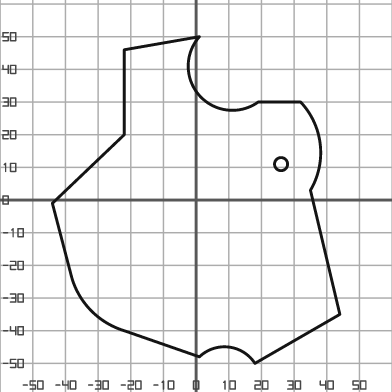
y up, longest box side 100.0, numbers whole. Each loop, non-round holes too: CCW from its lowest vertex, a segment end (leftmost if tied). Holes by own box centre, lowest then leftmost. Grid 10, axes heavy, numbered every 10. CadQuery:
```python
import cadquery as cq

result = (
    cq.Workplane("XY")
    .moveTo(18.0, -50.0)
    .lineTo(44.0, -35.0)
    .lineTo(35.0, 3.0)
    .threePointArc((38.0, 17.0), (32.0, 30.0))
    .lineTo(19.0, 30.0)
    .threePointArc((1.0, 32.0), (1.0, 50.0))
    .lineTo(-22.0, 46.0)
    .lineTo(-22.0, 20.0)
    .lineTo(-44.0, -1.0)
    .lineTo(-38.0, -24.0)
    .threePointArc((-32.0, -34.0), (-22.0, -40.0))
    .lineTo(1.0, -48.0)
    .threePointArc((10.0, -45.0), (18.0, -50.0))
    .close()
    .moveTo(26.0, 11.0)
    .circle(2.0)
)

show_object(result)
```